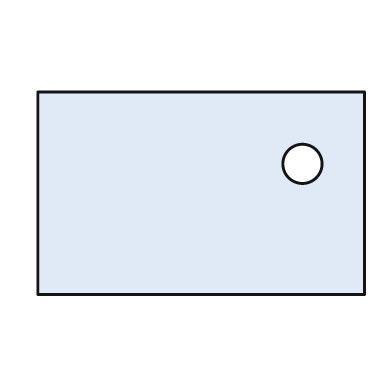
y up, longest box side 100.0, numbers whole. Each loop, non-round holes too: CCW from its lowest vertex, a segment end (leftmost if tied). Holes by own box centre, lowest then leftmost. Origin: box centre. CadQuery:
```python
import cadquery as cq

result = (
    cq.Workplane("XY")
    .moveTo(-50.0, -31.0)
    .lineTo(50.0, -31.0)
    .lineTo(50.0, 31.0)
    .lineTo(-50.0, 31.0)
    .close()
    .moveTo(31.0, 9.0)
    .circle(6.0)
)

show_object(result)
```